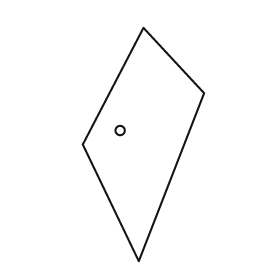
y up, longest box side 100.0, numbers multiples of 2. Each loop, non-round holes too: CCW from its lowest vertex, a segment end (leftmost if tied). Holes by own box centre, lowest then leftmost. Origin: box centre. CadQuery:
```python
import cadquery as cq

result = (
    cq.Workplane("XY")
    .moveTo(-2.0, -50.0)
    .lineTo(26.0, 22.0)
    .lineTo(0.0, 50.0)
    .lineTo(-26.0, 0.0)
    .close()
    .moveTo(-10.0, 6.0)
    .circle(2.0)
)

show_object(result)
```